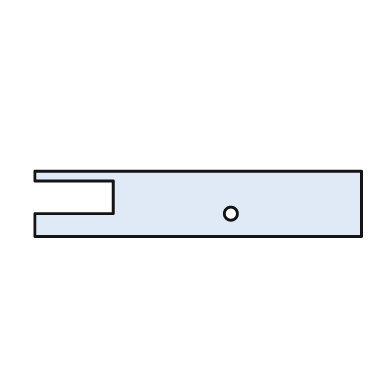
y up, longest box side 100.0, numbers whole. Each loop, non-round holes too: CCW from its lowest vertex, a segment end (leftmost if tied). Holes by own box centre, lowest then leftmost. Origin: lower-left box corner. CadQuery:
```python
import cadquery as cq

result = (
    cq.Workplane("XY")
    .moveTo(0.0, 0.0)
    .lineTo(100.0, 0.0)
    .lineTo(100.0, 20.0)
    .lineTo(0.0, 20.0)
    .lineTo(0.0, 17.0)
    .lineTo(24.0, 17.0)
    .lineTo(24.0, 7.0)
    .lineTo(0.0, 7.0)
    .close()
    .moveTo(60.0, 7.0)
    .circle(2.0)
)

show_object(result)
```